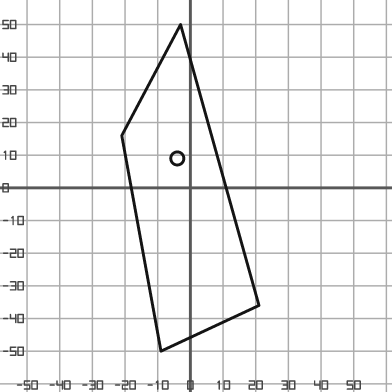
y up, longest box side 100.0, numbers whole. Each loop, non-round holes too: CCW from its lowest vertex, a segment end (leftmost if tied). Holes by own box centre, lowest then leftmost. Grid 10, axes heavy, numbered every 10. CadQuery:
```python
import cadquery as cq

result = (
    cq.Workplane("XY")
    .moveTo(-9.0, -50.0)
    .lineTo(21.0, -36.0)
    .lineTo(-3.0, 50.0)
    .lineTo(-21.0, 16.0)
    .close()
    .moveTo(-4.0, 9.0)
    .circle(2.0)
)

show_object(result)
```